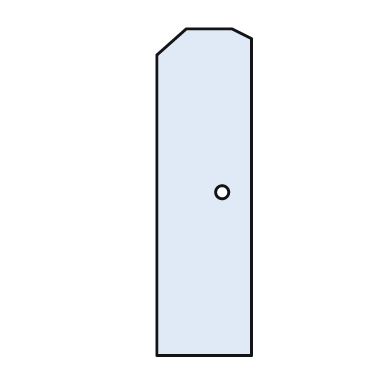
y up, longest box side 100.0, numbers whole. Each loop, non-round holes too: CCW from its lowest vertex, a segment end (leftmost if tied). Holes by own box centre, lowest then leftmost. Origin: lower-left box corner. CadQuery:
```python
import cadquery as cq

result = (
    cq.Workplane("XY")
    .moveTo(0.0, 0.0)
    .lineTo(29.0, 0.0)
    .lineTo(29.0, 97.0)
    .lineTo(23.0, 100.0)
    .lineTo(9.0, 100.0)
    .lineTo(0.0, 92.0)
    .close()
    .moveTo(20.0, 50.0)
    .circle(2.0)
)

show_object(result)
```